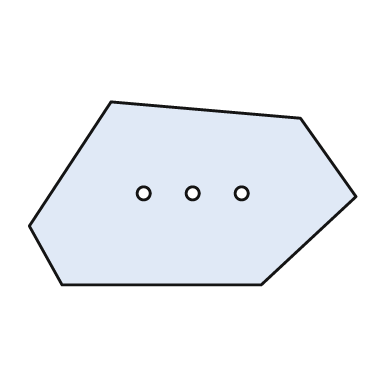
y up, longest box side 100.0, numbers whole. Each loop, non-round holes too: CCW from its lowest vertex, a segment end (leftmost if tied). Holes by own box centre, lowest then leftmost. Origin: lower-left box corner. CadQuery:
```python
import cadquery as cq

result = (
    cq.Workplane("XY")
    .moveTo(10.0, 0.0)
    .lineTo(71.0, 0.0)
    .lineTo(100.0, 27.0)
    .lineTo(83.0, 51.0)
    .lineTo(25.0, 56.0)
    .lineTo(0.0, 18.0)
    .close()
    .moveTo(35.0, 28.0)
    .circle(2.0)
    .moveTo(50.0, 28.0)
    .circle(2.0)
    .moveTo(65.0, 28.0)
    .circle(2.0)
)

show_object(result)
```